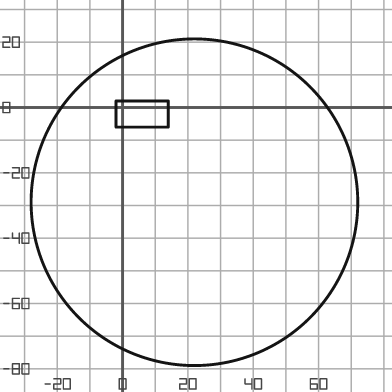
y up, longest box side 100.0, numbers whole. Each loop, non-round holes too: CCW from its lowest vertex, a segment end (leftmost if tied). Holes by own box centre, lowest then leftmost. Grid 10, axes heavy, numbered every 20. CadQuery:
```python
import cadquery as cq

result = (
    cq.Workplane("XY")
    .moveTo(22.0, -29.0)
    .circle(50.0)
    .moveTo(-2.0, -6.0)
    .lineTo(14.0, -6.0)
    .lineTo(14.0, 2.0)
    .lineTo(-2.0, 2.0)
    .close()
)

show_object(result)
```